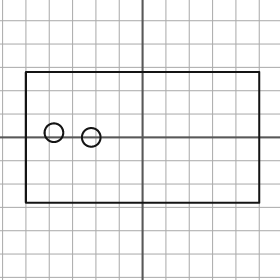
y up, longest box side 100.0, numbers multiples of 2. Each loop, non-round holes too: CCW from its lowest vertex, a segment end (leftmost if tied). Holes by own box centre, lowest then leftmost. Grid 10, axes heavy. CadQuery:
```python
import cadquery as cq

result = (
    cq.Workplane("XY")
    .moveTo(-50.0, -28.0)
    .lineTo(50.0, -28.0)
    .lineTo(50.0, 28.0)
    .lineTo(-50.0, 28.0)
    .close()
    .moveTo(-22.0, 0.0)
    .circle(4.0)
    .moveTo(-38.0, 2.0)
    .circle(4.0)
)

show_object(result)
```